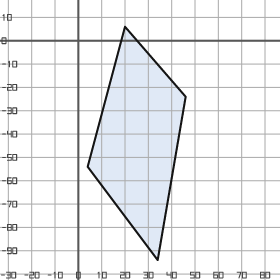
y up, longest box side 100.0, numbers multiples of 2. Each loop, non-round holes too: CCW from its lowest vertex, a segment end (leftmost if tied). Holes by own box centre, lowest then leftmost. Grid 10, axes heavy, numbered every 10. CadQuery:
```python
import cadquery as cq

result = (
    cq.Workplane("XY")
    .moveTo(34.0, -94.0)
    .lineTo(46.0, -24.0)
    .lineTo(20.0, 6.0)
    .lineTo(4.0, -54.0)
    .close()
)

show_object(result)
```